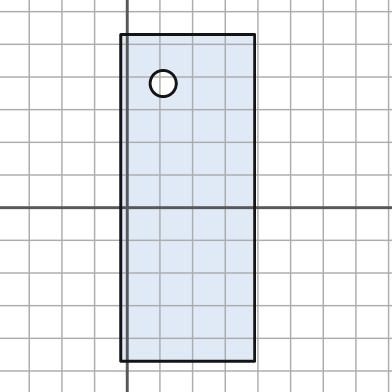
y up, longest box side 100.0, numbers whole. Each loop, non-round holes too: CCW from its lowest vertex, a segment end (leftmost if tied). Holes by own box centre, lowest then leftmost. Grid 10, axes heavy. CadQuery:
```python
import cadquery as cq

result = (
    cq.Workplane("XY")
    .moveTo(-2.0, -47.0)
    .lineTo(39.0, -47.0)
    .lineTo(39.0, 53.0)
    .lineTo(-2.0, 53.0)
    .close()
    .moveTo(11.0, 38.0)
    .circle(4.0)
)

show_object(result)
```